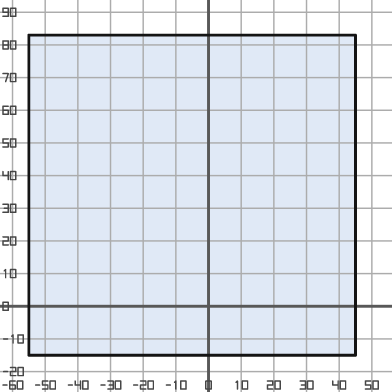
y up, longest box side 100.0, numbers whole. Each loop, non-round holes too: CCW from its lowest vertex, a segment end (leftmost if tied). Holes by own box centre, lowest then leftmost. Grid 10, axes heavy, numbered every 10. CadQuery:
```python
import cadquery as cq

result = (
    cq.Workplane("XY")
    .moveTo(-55.0, -15.0)
    .lineTo(45.0, -15.0)
    .lineTo(45.0, 83.0)
    .lineTo(-55.0, 83.0)
    .close()
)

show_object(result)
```